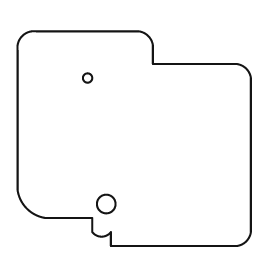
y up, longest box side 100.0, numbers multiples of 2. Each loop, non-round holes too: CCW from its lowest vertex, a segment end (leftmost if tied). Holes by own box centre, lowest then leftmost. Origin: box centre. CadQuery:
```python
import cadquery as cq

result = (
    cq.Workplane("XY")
    .moveTo(-10.0, -46.0)
    .lineTo(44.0, -46.0)
    .threePointArc((48.0, -44.0), (50.0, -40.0))
    .lineTo(50.0, 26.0)
    .threePointArc((48.0, 30.0), (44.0, 32.0))
    .lineTo(8.0, 32.0)
    .lineTo(8.0, 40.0)
    .threePointArc((6.0, 44.0), (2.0, 46.0))
    .lineTo(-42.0, 46.0)
    .threePointArc((-48.0, 44.0), (-50.0, 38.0))
    .lineTo(-50.0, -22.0)
    .threePointArc((-46.0, -30.0), (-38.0, -34.0))
    .lineTo(-18.0, -34.0)
    .lineTo(-18.0, -40.0)
    .threePointArc((-14.0, -42.0), (-10.0, -40.0))
    .close()
    .moveTo(-12.0, -28.0)
    .circle(4.0)
    .moveTo(-20.0, 26.0)
    .circle(2.0)
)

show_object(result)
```